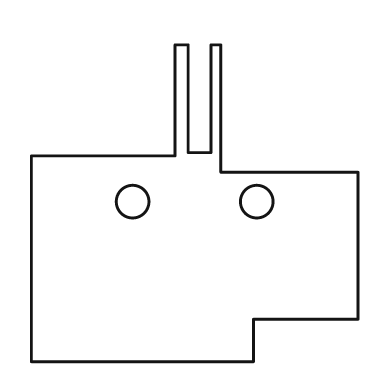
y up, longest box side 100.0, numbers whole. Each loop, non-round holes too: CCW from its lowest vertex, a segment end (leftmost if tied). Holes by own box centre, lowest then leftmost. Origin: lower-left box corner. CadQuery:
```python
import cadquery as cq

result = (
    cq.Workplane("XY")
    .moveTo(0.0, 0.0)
    .lineTo(68.0, 0.0)
    .lineTo(68.0, 13.0)
    .lineTo(100.0, 13.0)
    .lineTo(100.0, 58.0)
    .lineTo(58.0, 58.0)
    .lineTo(58.0, 97.0)
    .lineTo(55.0, 97.0)
    .lineTo(55.0, 64.0)
    .lineTo(48.0, 64.0)
    .lineTo(48.0, 97.0)
    .lineTo(44.0, 97.0)
    .lineTo(44.0, 63.0)
    .lineTo(0.0, 63.0)
    .close()
    .moveTo(31.0, 49.0)
    .circle(5.0)
    .moveTo(69.0, 49.0)
    .circle(5.0)
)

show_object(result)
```